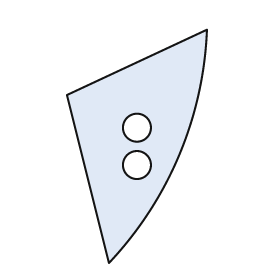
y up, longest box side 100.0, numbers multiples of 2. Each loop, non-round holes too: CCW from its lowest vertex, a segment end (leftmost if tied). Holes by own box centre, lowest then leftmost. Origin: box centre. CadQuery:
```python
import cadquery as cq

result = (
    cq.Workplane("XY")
    .moveTo(-12.0, -50.0)
    .threePointArc((18.0, -4.0), (30.0, 50.0))
    .lineTo(-30.0, 22.0)
    .close()
    .moveTo(0.0, -8.0)
    .circle(6.0)
    .moveTo(0.0, 8.0)
    .circle(6.0)
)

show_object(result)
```